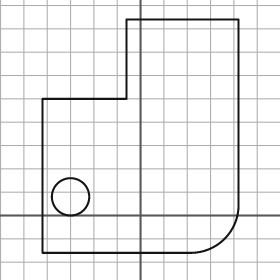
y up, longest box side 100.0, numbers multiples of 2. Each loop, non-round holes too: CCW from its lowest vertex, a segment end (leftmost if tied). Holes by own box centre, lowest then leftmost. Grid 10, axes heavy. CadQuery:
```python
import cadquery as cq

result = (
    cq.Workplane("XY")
    .moveTo(-42.0, -16.0)
    .lineTo(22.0, -16.0)
    .threePointArc((36.0, -10.0), (42.0, 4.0))
    .lineTo(42.0, 84.0)
    .lineTo(-6.0, 84.0)
    .lineTo(-6.0, 50.0)
    .lineTo(-42.0, 50.0)
    .close()
    .moveTo(-30.0, 8.0)
    .circle(8.0)
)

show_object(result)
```